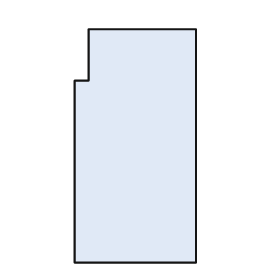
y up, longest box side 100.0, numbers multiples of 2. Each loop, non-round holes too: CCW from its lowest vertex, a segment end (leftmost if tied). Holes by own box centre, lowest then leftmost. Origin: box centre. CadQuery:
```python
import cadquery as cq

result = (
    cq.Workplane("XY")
    .moveTo(-26.0, -50.0)
    .lineTo(26.0, -50.0)
    .lineTo(26.0, 50.0)
    .lineTo(-20.0, 50.0)
    .lineTo(-20.0, 28.0)
    .lineTo(-26.0, 28.0)
    .close()
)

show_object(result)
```